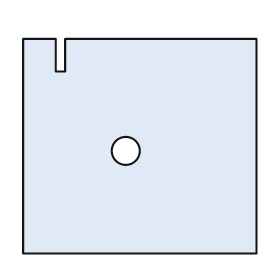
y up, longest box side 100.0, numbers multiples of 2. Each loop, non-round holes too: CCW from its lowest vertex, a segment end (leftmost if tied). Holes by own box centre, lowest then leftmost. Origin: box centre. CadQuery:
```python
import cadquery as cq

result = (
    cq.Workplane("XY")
    .moveTo(-50.0, -46.0)
    .lineTo(50.0, -46.0)
    .lineTo(50.0, 46.0)
    .lineTo(-32.0, 46.0)
    .lineTo(-32.0, 32.0)
    .lineTo(-36.0, 32.0)
    .lineTo(-36.0, 46.0)
    .lineTo(-50.0, 46.0)
    .close()
    .moveTo(-6.0, -2.0)
    .circle(6.0)
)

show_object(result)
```